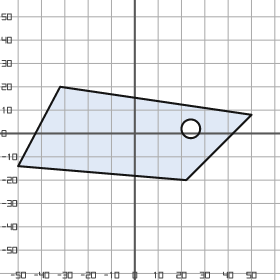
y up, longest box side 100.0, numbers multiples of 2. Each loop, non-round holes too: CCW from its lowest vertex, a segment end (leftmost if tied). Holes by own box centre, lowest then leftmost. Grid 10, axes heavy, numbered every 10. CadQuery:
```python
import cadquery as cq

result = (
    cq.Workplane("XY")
    .moveTo(22.0, -20.0)
    .lineTo(50.0, 8.0)
    .lineTo(-32.0, 20.0)
    .lineTo(-50.0, -14.0)
    .close()
    .moveTo(24.0, 2.0)
    .circle(4.0)
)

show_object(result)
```